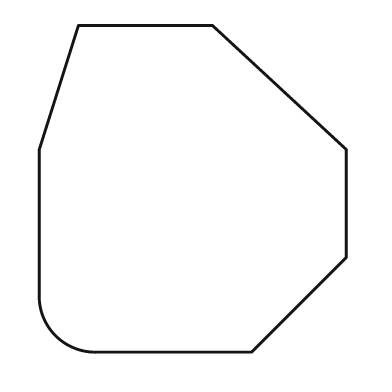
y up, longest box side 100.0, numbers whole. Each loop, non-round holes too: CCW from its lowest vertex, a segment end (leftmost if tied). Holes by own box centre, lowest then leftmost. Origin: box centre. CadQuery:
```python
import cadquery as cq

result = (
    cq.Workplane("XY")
    .moveTo(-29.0, -50.0)
    .lineTo(18.0, -50.0)
    .lineTo(47.0, -21.0)
    .lineTo(47.0, 12.0)
    .lineTo(6.0, 50.0)
    .lineTo(-35.0, 50.0)
    .lineTo(-47.0, 12.0)
    .lineTo(-47.0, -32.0)
    .threePointArc((-42.0, -45.0), (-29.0, -50.0))
    .close()
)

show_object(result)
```